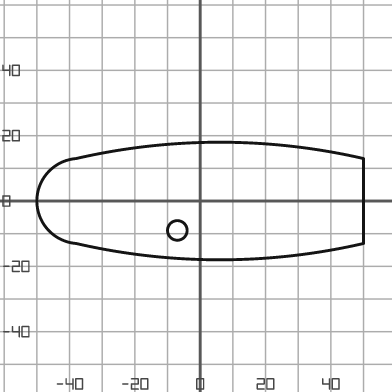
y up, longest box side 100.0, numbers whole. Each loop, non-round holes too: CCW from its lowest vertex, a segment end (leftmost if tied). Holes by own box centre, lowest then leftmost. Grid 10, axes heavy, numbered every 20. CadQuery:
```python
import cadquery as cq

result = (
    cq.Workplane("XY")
    .moveTo(-38.0, -13.0)
    .threePointArc((6.0, -18.0), (50.0, -13.0))
    .lineTo(50.0, 13.0)
    .threePointArc((6.0, 18.0), (-38.0, 13.0))
    .threePointArc((-50.0, 0.0), (-38.0, -13.0))
    .close()
    .moveTo(-7.0, -9.0)
    .circle(3.0)
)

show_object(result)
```